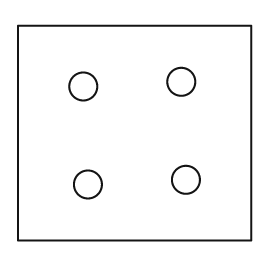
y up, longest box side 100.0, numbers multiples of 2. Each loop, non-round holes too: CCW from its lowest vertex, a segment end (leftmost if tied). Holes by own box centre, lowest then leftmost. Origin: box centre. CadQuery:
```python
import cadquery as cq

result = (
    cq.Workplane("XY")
    .moveTo(-50.0, -46.0)
    .lineTo(50.0, -46.0)
    .lineTo(50.0, 46.0)
    .lineTo(-50.0, 46.0)
    .close()
    .moveTo(-20.0, -22.0)
    .circle(6.0)
    .moveTo(22.0, -20.0)
    .circle(6.0)
    .moveTo(-22.0, 20.0)
    .circle(6.0)
    .moveTo(20.0, 22.0)
    .circle(6.0)
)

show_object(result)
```